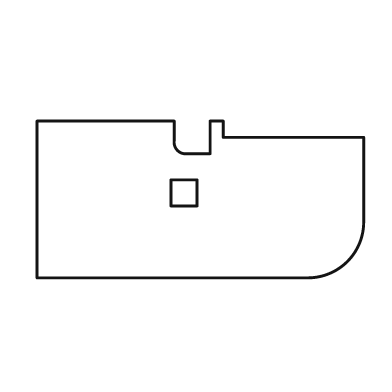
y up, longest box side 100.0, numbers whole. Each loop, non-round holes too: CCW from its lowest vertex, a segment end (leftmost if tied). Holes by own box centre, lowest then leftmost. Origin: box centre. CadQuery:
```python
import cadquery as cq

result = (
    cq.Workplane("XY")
    .moveTo(-50.0, -24.0)
    .lineTo(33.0, -24.0)
    .threePointArc((45.0, -19.0), (50.0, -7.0))
    .lineTo(50.0, 19.0)
    .lineTo(7.0, 19.0)
    .lineTo(7.0, 24.0)
    .lineTo(3.0, 24.0)
    .lineTo(3.0, 14.0)
    .lineTo(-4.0, 14.0)
    .threePointArc((-7.0, 15.0), (-8.0, 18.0))
    .lineTo(-8.0, 24.0)
    .lineTo(-50.0, 24.0)
    .close()
    .moveTo(-9.0, -2.0)
    .lineTo(-1.0, -2.0)
    .lineTo(-1.0, 6.0)
    .lineTo(-9.0, 6.0)
    .close()
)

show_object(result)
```